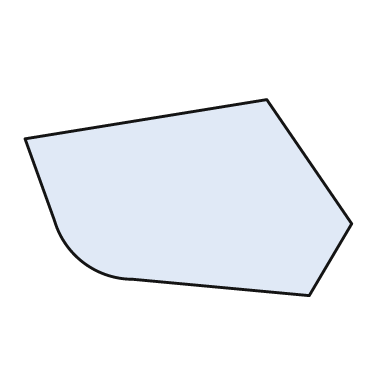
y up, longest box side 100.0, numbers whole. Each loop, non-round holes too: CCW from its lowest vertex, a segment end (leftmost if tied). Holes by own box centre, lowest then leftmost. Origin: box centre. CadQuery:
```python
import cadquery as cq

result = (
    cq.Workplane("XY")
    .moveTo(37.0, -30.0)
    .lineTo(50.0, -8.0)
    .lineTo(24.0, 30.0)
    .lineTo(-50.0, 18.0)
    .lineTo(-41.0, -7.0)
    .threePointArc((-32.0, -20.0), (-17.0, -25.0))
    .close()
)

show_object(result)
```